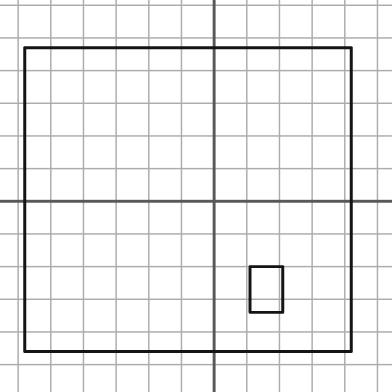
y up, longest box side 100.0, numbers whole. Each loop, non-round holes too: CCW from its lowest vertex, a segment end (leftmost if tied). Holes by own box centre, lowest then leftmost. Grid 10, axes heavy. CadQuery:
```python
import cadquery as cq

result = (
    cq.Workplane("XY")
    .moveTo(-58.0, -46.0)
    .lineTo(42.0, -46.0)
    .lineTo(42.0, 47.0)
    .lineTo(-58.0, 47.0)
    .close()
    .moveTo(11.0, -34.0)
    .lineTo(21.0, -34.0)
    .lineTo(21.0, -20.0)
    .lineTo(11.0, -20.0)
    .close()
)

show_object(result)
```